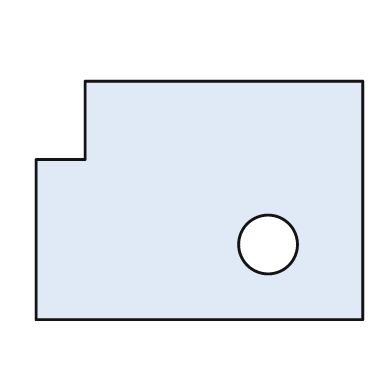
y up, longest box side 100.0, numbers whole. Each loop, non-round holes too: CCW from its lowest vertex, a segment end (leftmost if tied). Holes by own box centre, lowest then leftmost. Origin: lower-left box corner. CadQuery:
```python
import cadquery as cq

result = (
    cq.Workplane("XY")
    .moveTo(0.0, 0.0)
    .lineTo(100.0, 0.0)
    .lineTo(100.0, 73.0)
    .lineTo(15.0, 73.0)
    .lineTo(15.0, 49.0)
    .lineTo(0.0, 49.0)
    .close()
    .moveTo(71.0, 23.0)
    .circle(9.0)
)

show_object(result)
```